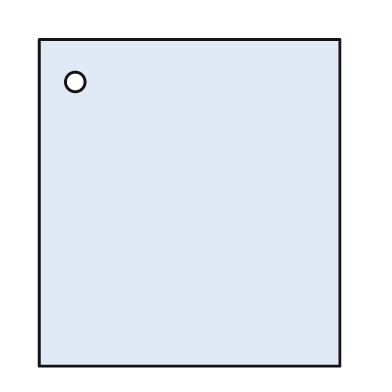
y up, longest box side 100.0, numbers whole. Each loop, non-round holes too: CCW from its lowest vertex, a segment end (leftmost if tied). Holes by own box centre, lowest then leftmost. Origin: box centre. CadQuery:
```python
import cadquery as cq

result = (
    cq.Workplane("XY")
    .moveTo(-46.0, -50.0)
    .lineTo(46.0, -50.0)
    .lineTo(46.0, 50.0)
    .lineTo(-46.0, 50.0)
    .close()
    .moveTo(-35.0, 37.0)
    .circle(3.0)
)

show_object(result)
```